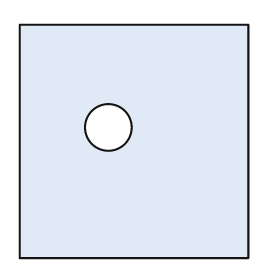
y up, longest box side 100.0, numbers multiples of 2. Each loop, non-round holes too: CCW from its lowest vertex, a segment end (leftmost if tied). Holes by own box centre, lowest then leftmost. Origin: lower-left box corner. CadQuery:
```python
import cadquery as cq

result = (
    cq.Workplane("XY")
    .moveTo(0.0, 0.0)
    .lineTo(98.0, 0.0)
    .lineTo(98.0, 100.0)
    .lineTo(0.0, 100.0)
    .close()
    .moveTo(38.0, 56.0)
    .circle(10.0)
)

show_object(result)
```